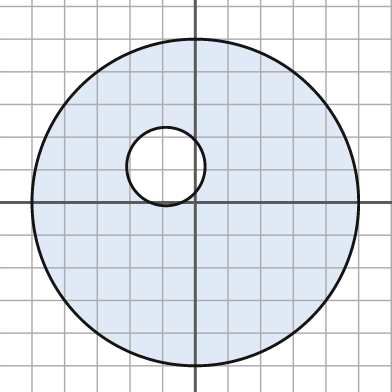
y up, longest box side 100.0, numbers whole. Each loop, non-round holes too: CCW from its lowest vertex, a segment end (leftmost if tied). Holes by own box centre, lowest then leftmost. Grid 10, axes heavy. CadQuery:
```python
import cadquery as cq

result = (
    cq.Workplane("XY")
    .moveTo(0.0, 0.0)
    .circle(50.0)
    .moveTo(-9.0, 11.0)
    .circle(12.0)
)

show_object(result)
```